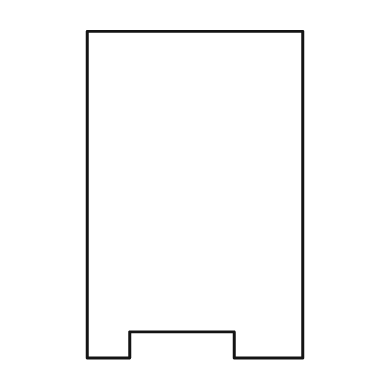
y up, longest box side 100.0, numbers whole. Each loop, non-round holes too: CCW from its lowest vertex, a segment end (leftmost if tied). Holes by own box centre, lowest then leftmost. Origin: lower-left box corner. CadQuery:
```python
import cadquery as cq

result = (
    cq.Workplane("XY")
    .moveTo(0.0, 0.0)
    .lineTo(13.0, 0.0)
    .lineTo(13.0, 8.0)
    .lineTo(45.0, 8.0)
    .lineTo(45.0, 0.0)
    .lineTo(66.0, 0.0)
    .lineTo(66.0, 100.0)
    .lineTo(0.0, 100.0)
    .close()
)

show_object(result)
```